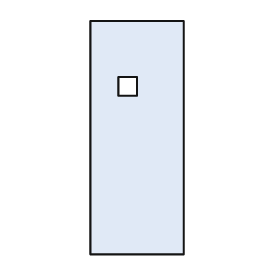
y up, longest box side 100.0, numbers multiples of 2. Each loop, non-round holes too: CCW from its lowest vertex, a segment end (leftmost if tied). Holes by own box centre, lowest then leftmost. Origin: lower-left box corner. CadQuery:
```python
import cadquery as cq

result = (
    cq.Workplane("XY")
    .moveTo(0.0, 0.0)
    .lineTo(40.0, 0.0)
    .lineTo(40.0, 100.0)
    .lineTo(0.0, 100.0)
    .close()
    .moveTo(12.0, 68.0)
    .lineTo(20.0, 68.0)
    .lineTo(20.0, 76.0)
    .lineTo(12.0, 76.0)
    .close()
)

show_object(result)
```